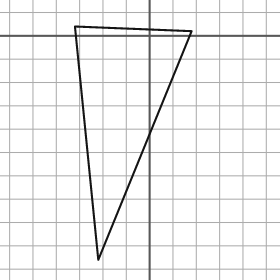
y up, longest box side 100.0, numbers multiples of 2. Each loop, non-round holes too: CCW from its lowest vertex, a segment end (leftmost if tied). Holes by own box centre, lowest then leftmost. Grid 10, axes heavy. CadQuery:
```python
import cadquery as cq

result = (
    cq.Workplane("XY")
    .moveTo(-22.0, -96.0)
    .lineTo(18.0, 2.0)
    .lineTo(-32.0, 4.0)
    .close()
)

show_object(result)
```